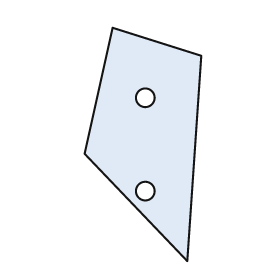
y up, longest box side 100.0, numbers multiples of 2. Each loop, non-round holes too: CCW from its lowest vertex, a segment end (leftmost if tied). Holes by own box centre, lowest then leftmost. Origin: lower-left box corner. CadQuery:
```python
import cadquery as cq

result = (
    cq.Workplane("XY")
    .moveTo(44.0, 0.0)
    .lineTo(50.0, 88.0)
    .lineTo(12.0, 100.0)
    .lineTo(0.0, 46.0)
    .close()
    .moveTo(26.0, 30.0)
    .circle(4.0)
    .moveTo(26.0, 70.0)
    .circle(4.0)
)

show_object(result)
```